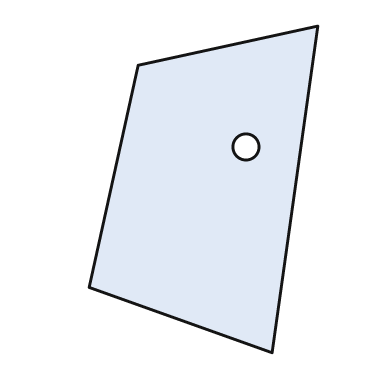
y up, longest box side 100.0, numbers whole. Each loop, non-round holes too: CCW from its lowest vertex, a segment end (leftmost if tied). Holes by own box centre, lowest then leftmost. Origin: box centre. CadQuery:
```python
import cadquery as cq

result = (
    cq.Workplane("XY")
    .moveTo(21.0, -50.0)
    .lineTo(35.0, 50.0)
    .lineTo(-20.0, 38.0)
    .lineTo(-35.0, -30.0)
    .close()
    .moveTo(13.0, 13.0)
    .circle(4.0)
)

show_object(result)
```